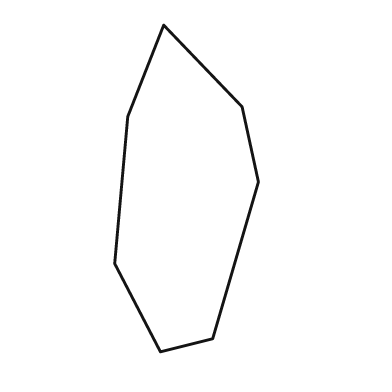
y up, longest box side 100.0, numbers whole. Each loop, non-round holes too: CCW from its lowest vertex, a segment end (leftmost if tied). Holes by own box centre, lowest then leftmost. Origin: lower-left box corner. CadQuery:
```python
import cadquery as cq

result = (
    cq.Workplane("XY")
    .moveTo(14.0, 0.0)
    .lineTo(30.0, 4.0)
    .lineTo(44.0, 52.0)
    .lineTo(39.0, 75.0)
    .lineTo(15.0, 100.0)
    .lineTo(4.0, 72.0)
    .lineTo(0.0, 27.0)
    .close()
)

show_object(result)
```